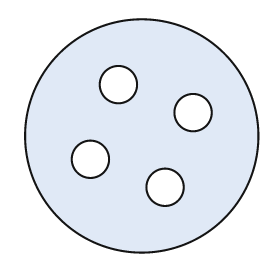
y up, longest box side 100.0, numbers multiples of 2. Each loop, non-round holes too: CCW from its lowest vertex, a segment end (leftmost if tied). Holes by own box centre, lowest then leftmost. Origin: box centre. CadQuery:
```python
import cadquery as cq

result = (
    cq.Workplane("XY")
    .moveTo(0.0, 0.0)
    .circle(50.0)
    .moveTo(10.0, -22.0)
    .circle(8.0)
    .moveTo(-22.0, -10.0)
    .circle(8.0)
    .moveTo(22.0, 10.0)
    .circle(8.0)
    .moveTo(-10.0, 22.0)
    .circle(8.0)
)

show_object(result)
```